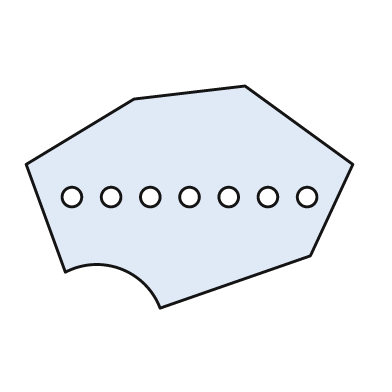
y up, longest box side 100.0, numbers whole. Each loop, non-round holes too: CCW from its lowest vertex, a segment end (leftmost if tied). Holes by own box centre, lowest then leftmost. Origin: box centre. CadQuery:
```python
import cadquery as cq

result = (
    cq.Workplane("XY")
    .moveTo(-9.0, -34.0)
    .lineTo(37.0, -18.0)
    .lineTo(50.0, 10.0)
    .lineTo(17.0, 34.0)
    .lineTo(-17.0, 30.0)
    .lineTo(-50.0, 10.0)
    .lineTo(-38.0, -23.0)
    .threePointArc((-21.0, -22.0), (-9.0, -34.0))
    .close()
    .moveTo(-36.0, 0.0)
    .circle(3.0)
    .moveTo(-24.0, 0.0)
    .circle(3.0)
    .moveTo(-12.0, 0.0)
    .circle(3.0)
    .moveTo(0.0, 0.0)
    .circle(3.0)
    .moveTo(12.0, 0.0)
    .circle(3.0)
    .moveTo(24.0, 0.0)
    .circle(3.0)
    .moveTo(36.0, 0.0)
    .circle(3.0)
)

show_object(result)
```